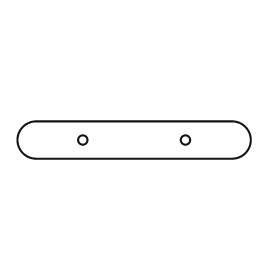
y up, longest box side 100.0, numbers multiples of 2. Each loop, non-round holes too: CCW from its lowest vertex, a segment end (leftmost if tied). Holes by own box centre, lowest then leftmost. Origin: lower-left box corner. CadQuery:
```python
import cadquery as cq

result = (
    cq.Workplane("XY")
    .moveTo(8.0, 0.0)
    .lineTo(92.0, 0.0)
    .threePointArc((100.0, 8.0), (92.0, 16.0))
    .lineTo(8.0, 16.0)
    .threePointArc((0.0, 8.0), (8.0, 0.0))
    .close()
    .moveTo(28.0, 8.0)
    .circle(2.0)
    .moveTo(72.0, 8.0)
    .circle(2.0)
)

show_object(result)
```